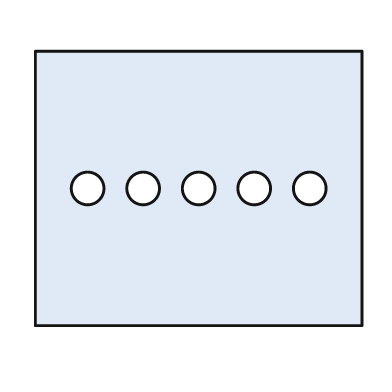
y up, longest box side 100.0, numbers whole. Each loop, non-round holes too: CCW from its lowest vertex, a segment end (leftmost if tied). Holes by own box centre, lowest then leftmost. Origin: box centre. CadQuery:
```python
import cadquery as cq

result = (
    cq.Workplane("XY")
    .moveTo(-50.0, -42.0)
    .lineTo(50.0, -42.0)
    .lineTo(50.0, 42.0)
    .lineTo(-50.0, 42.0)
    .close()
    .moveTo(-34.0, 0.0)
    .circle(5.0)
    .moveTo(-17.0, 0.0)
    .circle(5.0)
    .moveTo(0.0, 0.0)
    .circle(5.0)
    .moveTo(17.0, 0.0)
    .circle(5.0)
    .moveTo(34.0, 0.0)
    .circle(5.0)
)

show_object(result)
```